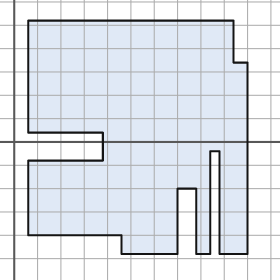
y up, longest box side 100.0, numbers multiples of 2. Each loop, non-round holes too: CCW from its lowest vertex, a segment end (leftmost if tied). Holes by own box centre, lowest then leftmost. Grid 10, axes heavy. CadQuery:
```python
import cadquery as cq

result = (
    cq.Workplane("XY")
    .moveTo(46.0, -48.0)
    .lineTo(70.0, -48.0)
    .lineTo(70.0, -20.0)
    .lineTo(78.0, -20.0)
    .lineTo(78.0, -48.0)
    .lineTo(84.0, -48.0)
    .lineTo(84.0, -4.0)
    .lineTo(88.0, -4.0)
    .lineTo(88.0, -48.0)
    .lineTo(100.0, -48.0)
    .lineTo(100.0, 34.0)
    .lineTo(94.0, 34.0)
    .lineTo(94.0, 52.0)
    .lineTo(6.0, 52.0)
    .lineTo(6.0, 4.0)
    .lineTo(38.0, 4.0)
    .lineTo(38.0, -8.0)
    .lineTo(6.0, -8.0)
    .lineTo(6.0, -40.0)
    .lineTo(46.0, -40.0)
    .close()
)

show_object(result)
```